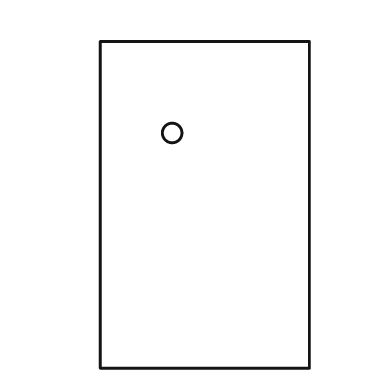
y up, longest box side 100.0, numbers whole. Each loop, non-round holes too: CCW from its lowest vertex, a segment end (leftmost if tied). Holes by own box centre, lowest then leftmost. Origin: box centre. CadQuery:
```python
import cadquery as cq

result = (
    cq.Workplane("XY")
    .moveTo(-32.0, -50.0)
    .lineTo(32.0, -50.0)
    .lineTo(32.0, 50.0)
    .lineTo(-32.0, 50.0)
    .close()
    .moveTo(-10.0, 22.0)
    .circle(3.0)
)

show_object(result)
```